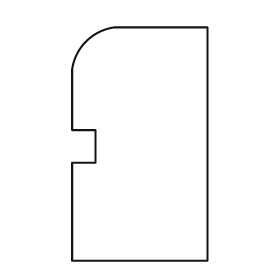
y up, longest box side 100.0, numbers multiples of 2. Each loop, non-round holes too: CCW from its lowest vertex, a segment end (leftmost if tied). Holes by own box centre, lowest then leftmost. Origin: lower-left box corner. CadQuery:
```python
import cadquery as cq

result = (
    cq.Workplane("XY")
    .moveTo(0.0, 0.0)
    .lineTo(58.0, 0.0)
    .lineTo(58.0, 100.0)
    .lineTo(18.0, 100.0)
    .threePointArc((6.0, 94.0), (0.0, 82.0))
    .lineTo(0.0, 56.0)
    .lineTo(10.0, 56.0)
    .lineTo(10.0, 42.0)
    .lineTo(0.0, 42.0)
    .close()
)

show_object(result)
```